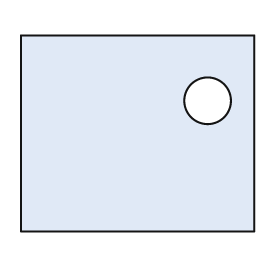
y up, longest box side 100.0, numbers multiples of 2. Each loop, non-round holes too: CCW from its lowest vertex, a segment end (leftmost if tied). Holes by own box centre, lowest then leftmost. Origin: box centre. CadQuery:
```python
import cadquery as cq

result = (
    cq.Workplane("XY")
    .moveTo(-50.0, -42.0)
    .lineTo(50.0, -42.0)
    .lineTo(50.0, 42.0)
    .lineTo(-50.0, 42.0)
    .close()
    .moveTo(30.0, 14.0)
    .circle(10.0)
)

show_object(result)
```